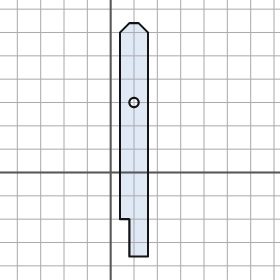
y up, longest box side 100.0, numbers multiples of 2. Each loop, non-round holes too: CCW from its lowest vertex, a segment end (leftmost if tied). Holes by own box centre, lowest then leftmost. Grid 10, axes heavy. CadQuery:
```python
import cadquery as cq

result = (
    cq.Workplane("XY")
    .moveTo(8.0, -36.0)
    .lineTo(16.0, -36.0)
    .lineTo(16.0, 60.0)
    .lineTo(12.0, 64.0)
    .lineTo(8.0, 64.0)
    .lineTo(4.0, 60.0)
    .lineTo(4.0, -20.0)
    .lineTo(8.0, -20.0)
    .close()
    .moveTo(10.0, 30.0)
    .circle(2.0)
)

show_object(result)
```